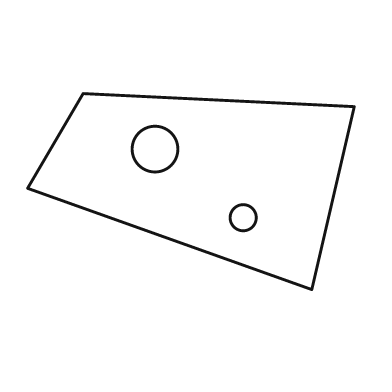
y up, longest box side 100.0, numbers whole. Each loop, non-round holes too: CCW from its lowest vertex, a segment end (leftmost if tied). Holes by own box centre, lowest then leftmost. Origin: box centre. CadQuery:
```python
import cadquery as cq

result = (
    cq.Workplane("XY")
    .moveTo(37.0, -30.0)
    .lineTo(50.0, 26.0)
    .lineTo(-33.0, 30.0)
    .lineTo(-50.0, 1.0)
    .close()
    .moveTo(16.0, -8.0)
    .circle(4.0)
    .moveTo(-11.0, 13.0)
    .circle(7.0)
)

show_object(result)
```